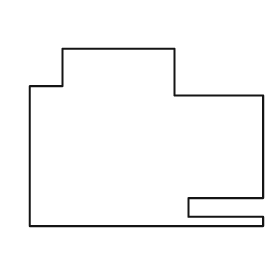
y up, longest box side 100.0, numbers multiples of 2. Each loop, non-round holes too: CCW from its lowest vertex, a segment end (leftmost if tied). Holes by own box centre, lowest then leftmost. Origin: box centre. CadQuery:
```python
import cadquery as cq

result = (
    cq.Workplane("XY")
    .moveTo(-50.0, -38.0)
    .lineTo(50.0, -38.0)
    .lineTo(50.0, -34.0)
    .lineTo(18.0, -34.0)
    .lineTo(18.0, -26.0)
    .lineTo(50.0, -26.0)
    .lineTo(50.0, 18.0)
    .lineTo(12.0, 18.0)
    .lineTo(12.0, 38.0)
    .lineTo(-36.0, 38.0)
    .lineTo(-36.0, 22.0)
    .lineTo(-50.0, 22.0)
    .close()
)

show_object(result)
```